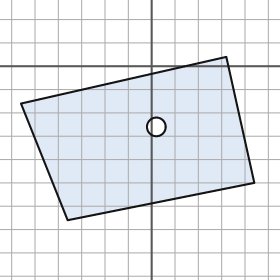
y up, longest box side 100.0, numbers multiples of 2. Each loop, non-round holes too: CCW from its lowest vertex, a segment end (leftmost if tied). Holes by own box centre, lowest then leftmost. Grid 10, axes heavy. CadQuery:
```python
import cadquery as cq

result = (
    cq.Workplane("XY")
    .moveTo(-36.0, -66.0)
    .lineTo(44.0, -50.0)
    .lineTo(32.0, 4.0)
    .lineTo(-56.0, -16.0)
    .close()
    .moveTo(2.0, -26.0)
    .circle(4.0)
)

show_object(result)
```